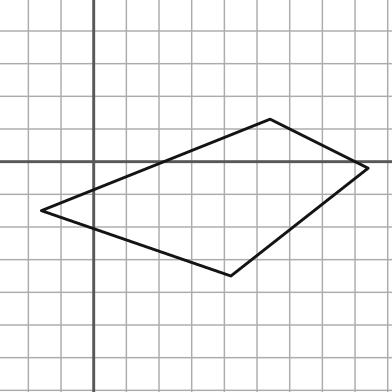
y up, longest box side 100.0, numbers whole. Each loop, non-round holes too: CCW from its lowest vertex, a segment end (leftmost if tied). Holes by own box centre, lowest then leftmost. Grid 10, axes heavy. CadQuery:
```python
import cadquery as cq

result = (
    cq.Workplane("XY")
    .moveTo(42.0, -35.0)
    .lineTo(84.0, -2.0)
    .lineTo(54.0, 13.0)
    .lineTo(-16.0, -15.0)
    .close()
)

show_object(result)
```